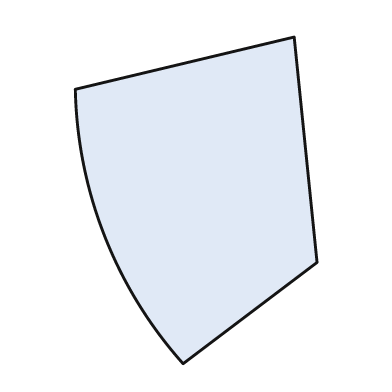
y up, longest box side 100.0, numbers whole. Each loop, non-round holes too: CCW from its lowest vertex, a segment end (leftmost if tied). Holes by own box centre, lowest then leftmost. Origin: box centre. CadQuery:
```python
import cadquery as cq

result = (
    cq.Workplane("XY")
    .moveTo(-4.0, -50.0)
    .lineTo(37.0, -19.0)
    .lineTo(30.0, 50.0)
    .lineTo(-37.0, 34.0)
    .threePointArc((-28.0, -11.0), (-4.0, -50.0))
    .close()
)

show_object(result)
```